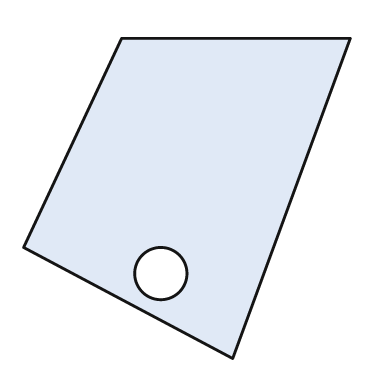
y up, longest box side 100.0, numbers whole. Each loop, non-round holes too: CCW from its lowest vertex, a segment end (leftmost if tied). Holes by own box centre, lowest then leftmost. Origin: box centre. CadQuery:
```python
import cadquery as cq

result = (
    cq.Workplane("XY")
    .moveTo(14.0, -49.0)
    .lineTo(50.0, 49.0)
    .lineTo(-20.0, 49.0)
    .lineTo(-50.0, -15.0)
    .close()
    .moveTo(-8.0, -23.0)
    .circle(8.0)
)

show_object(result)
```